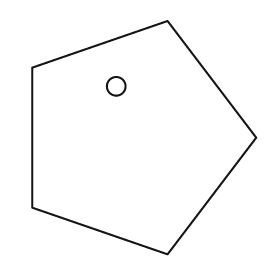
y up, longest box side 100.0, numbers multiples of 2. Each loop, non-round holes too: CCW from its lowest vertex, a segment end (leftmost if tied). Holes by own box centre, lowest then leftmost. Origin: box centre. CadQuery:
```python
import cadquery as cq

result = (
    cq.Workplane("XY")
    .moveTo(10.0, -50.0)
    .lineTo(48.0, 0.0)
    .lineTo(10.0, 50.0)
    .lineTo(-48.0, 30.0)
    .lineTo(-48.0, -30.0)
    .close()
    .moveTo(-12.0, 22.0)
    .circle(4.0)
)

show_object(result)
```